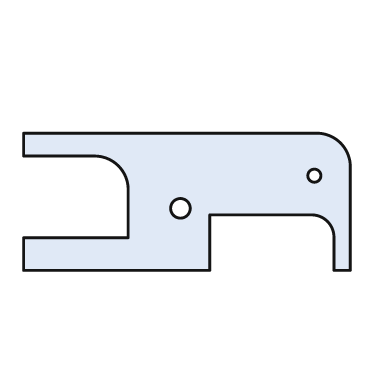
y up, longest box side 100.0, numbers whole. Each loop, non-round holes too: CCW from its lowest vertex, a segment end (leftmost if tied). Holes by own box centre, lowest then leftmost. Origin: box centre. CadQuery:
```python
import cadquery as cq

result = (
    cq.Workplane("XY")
    .moveTo(-50.0, -21.0)
    .lineTo(7.0, -21.0)
    .lineTo(7.0, -4.0)
    .lineTo(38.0, -4.0)
    .threePointArc((43.0, -6.0), (45.0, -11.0))
    .lineTo(45.0, -21.0)
    .lineTo(50.0, -21.0)
    .lineTo(50.0, 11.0)
    .threePointArc((47.0, 18.0), (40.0, 21.0))
    .lineTo(-50.0, 21.0)
    .lineTo(-50.0, 14.0)
    .lineTo(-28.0, 14.0)
    .threePointArc((-21.0, 11.0), (-18.0, 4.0))
    .lineTo(-18.0, -11.0)
    .lineTo(-50.0, -11.0)
    .close()
    .moveTo(-2.0, -2.0)
    .circle(3.0)
    .moveTo(39.0, 8.0)
    .circle(2.0)
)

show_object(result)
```